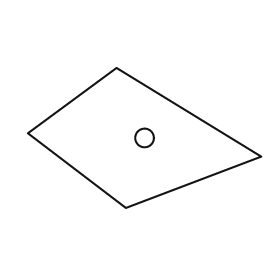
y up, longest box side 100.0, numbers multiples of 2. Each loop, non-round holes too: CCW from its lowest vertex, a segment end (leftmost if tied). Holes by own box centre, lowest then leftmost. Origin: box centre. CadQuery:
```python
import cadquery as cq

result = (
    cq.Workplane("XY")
    .moveTo(-8.0, -30.0)
    .lineTo(50.0, -8.0)
    .lineTo(-12.0, 30.0)
    .lineTo(-50.0, 2.0)
    .close()
    .moveTo(0.0, 0.0)
    .circle(4.0)
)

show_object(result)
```